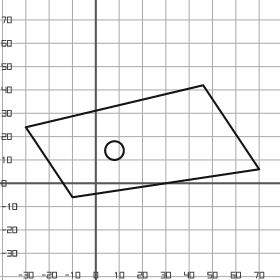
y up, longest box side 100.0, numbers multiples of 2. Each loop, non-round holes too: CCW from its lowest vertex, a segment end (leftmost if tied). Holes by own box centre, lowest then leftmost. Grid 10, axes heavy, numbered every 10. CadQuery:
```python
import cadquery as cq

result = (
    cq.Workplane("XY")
    .moveTo(-10.0, -6.0)
    .lineTo(70.0, 6.0)
    .lineTo(46.0, 42.0)
    .lineTo(-30.0, 24.0)
    .close()
    .moveTo(8.0, 14.0)
    .circle(4.0)
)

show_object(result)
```